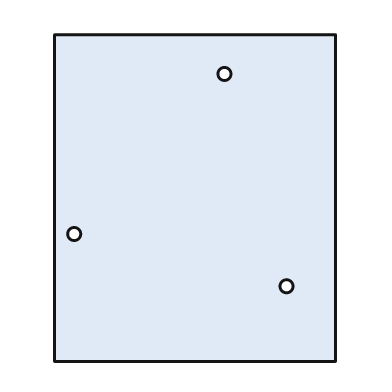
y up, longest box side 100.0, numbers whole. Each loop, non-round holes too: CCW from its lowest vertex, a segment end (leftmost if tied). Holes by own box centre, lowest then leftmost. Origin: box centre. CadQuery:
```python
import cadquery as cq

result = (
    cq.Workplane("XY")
    .moveTo(-43.0, -50.0)
    .lineTo(43.0, -50.0)
    .lineTo(43.0, 50.0)
    .lineTo(-43.0, 50.0)
    .close()
    .moveTo(28.0, -27.0)
    .circle(2.0)
    .moveTo(-37.0, -11.0)
    .circle(2.0)
    .moveTo(9.0, 38.0)
    .circle(2.0)
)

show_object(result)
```